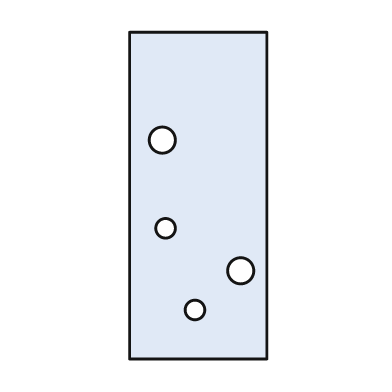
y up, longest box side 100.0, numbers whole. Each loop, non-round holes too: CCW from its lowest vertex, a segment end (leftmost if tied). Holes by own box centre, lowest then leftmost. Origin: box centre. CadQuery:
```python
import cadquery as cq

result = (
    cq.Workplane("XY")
    .moveTo(-21.0, -50.0)
    .lineTo(21.0, -50.0)
    .lineTo(21.0, 50.0)
    .lineTo(-21.0, 50.0)
    .close()
    .moveTo(-1.0, -35.0)
    .circle(3.0)
    .moveTo(13.0, -23.0)
    .circle(4.0)
    .moveTo(-10.0, -10.0)
    .circle(3.0)
    .moveTo(-11.0, 17.0)
    .circle(4.0)
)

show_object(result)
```